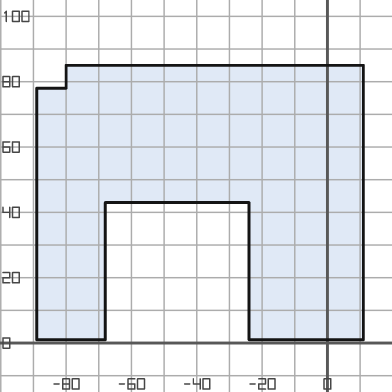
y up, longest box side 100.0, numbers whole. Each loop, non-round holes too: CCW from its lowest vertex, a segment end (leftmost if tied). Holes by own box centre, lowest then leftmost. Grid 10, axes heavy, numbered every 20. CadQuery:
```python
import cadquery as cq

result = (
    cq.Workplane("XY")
    .moveTo(-89.0, 1.0)
    .lineTo(-68.0, 1.0)
    .lineTo(-68.0, 43.0)
    .lineTo(-24.0, 43.0)
    .lineTo(-24.0, 1.0)
    .lineTo(11.0, 1.0)
    .lineTo(11.0, 85.0)
    .lineTo(-80.0, 85.0)
    .lineTo(-80.0, 78.0)
    .lineTo(-89.0, 78.0)
    .close()
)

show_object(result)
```